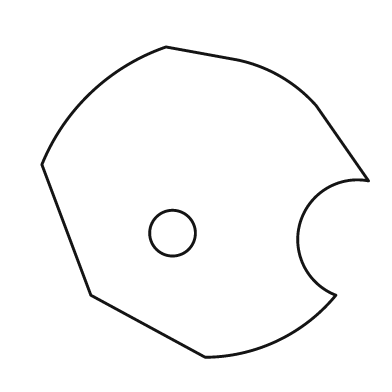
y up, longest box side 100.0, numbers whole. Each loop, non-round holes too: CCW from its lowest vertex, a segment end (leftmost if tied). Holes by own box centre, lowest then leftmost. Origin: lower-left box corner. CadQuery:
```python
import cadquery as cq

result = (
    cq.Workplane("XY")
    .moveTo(50.0, 0.0)
    .threePointArc((72.0, 5.0), (90.0, 19.0))
    .threePointArc((79.0, 41.0), (100.0, 54.0))
    .lineTo(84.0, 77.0)
    .threePointArc((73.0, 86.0), (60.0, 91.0))
    .lineTo(38.0, 95.0)
    .threePointArc((15.0, 81.0), (0.0, 59.0))
    .lineTo(15.0, 19.0)
    .close()
    .moveTo(40.0, 38.0)
    .circle(7.0)
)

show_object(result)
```